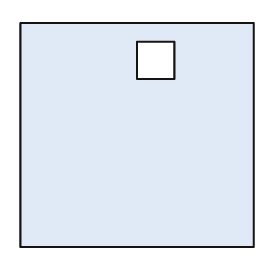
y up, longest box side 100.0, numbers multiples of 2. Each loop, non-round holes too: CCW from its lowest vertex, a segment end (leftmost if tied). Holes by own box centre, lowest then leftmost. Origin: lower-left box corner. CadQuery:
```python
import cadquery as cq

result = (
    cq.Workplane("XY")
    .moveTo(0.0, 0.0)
    .lineTo(100.0, 0.0)
    .lineTo(100.0, 96.0)
    .lineTo(0.0, 96.0)
    .close()
    .moveTo(50.0, 72.0)
    .lineTo(66.0, 72.0)
    .lineTo(66.0, 88.0)
    .lineTo(50.0, 88.0)
    .close()
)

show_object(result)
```